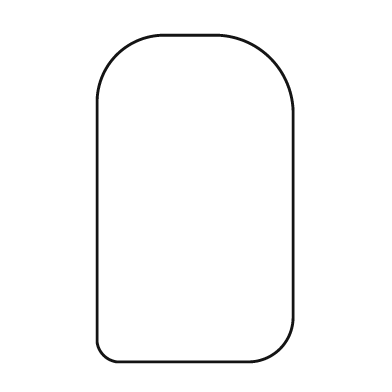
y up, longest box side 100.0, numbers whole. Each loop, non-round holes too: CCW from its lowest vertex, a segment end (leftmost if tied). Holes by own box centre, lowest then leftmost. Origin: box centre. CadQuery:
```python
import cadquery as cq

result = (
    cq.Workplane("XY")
    .moveTo(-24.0, -50.0)
    .lineTo(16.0, -50.0)
    .threePointArc((26.0, -46.0), (30.0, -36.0))
    .lineTo(30.0, 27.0)
    .threePointArc((23.0, 43.0), (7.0, 50.0))
    .lineTo(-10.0, 50.0)
    .threePointArc((-24.0, 44.0), (-30.0, 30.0))
    .lineTo(-30.0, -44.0)
    .threePointArc((-28.0, -48.0), (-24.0, -50.0))
    .close()
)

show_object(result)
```